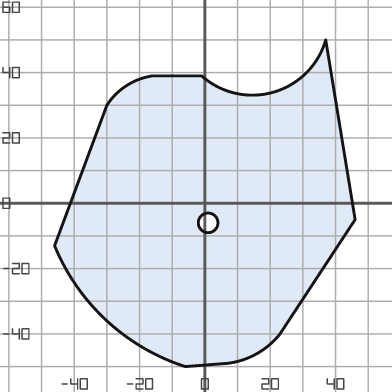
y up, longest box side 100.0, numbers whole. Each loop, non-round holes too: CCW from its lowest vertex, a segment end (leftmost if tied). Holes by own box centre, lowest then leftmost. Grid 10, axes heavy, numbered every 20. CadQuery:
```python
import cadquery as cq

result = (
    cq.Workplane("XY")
    .moveTo(-6.0, -50.0)
    .lineTo(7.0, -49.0)
    .threePointArc((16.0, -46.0), (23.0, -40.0))
    .lineTo(46.0, -5.0)
    .lineTo(37.0, 50.0)
    .threePointArc((21.0, 34.0), (-1.0, 39.0))
    .lineTo(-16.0, 39.0)
    .threePointArc((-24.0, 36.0), (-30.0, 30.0))
    .lineTo(-46.0, -13.0)
    .threePointArc((-30.0, -36.0), (-6.0, -50.0))
    .close()
    .moveTo(1.0, -6.0)
    .circle(3.0)
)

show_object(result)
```